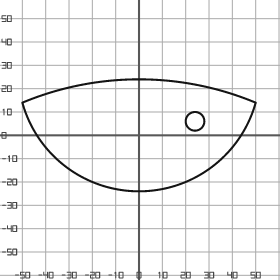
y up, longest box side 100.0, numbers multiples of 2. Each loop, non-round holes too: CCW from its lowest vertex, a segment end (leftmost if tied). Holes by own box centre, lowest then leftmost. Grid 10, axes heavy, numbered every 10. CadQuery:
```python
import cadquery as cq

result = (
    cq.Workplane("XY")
    .moveTo(-50.0, 14.0)
    .threePointArc((0.0, -24.0), (50.0, 14.0))
    .threePointArc((0.0, 24.0), (-50.0, 14.0))
    .close()
    .moveTo(24.0, 6.0)
    .circle(4.0)
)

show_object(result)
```